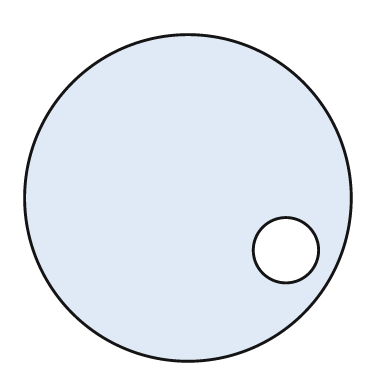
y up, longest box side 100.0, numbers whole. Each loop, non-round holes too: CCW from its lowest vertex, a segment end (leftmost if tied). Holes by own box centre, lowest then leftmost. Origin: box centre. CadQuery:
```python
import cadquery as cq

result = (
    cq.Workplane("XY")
    .moveTo(0.0, 0.0)
    .circle(50.0)
    .moveTo(30.0, -16.0)
    .circle(10.0)
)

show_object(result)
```